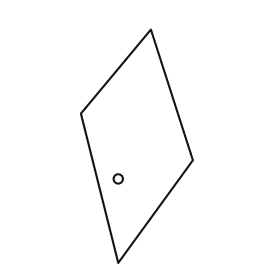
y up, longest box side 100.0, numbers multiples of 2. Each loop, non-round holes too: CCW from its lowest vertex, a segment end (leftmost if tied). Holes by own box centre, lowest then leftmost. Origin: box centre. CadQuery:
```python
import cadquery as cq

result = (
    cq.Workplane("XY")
    .moveTo(-8.0, -50.0)
    .lineTo(24.0, -6.0)
    .lineTo(6.0, 50.0)
    .lineTo(-24.0, 14.0)
    .close()
    .moveTo(-8.0, -14.0)
    .circle(2.0)
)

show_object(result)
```